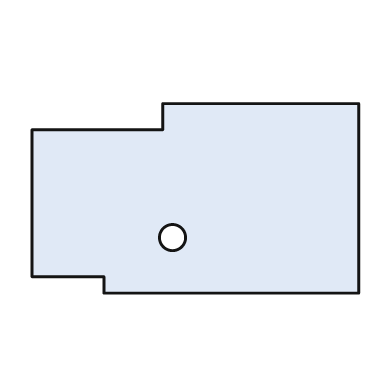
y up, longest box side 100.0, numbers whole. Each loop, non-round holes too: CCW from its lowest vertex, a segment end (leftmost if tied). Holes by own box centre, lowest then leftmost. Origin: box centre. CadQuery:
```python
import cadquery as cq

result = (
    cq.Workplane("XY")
    .moveTo(-28.0, -29.0)
    .lineTo(50.0, -29.0)
    .lineTo(50.0, 29.0)
    .lineTo(-10.0, 29.0)
    .lineTo(-10.0, 21.0)
    .lineTo(-50.0, 21.0)
    .lineTo(-50.0, -24.0)
    .lineTo(-28.0, -24.0)
    .close()
    .moveTo(-7.0, -12.0)
    .circle(4.0)
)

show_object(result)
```